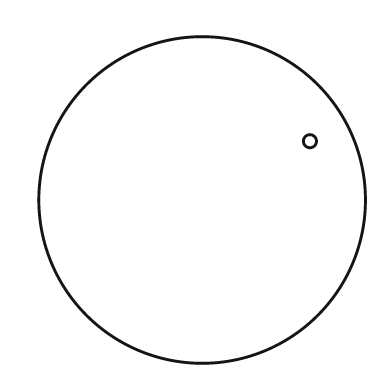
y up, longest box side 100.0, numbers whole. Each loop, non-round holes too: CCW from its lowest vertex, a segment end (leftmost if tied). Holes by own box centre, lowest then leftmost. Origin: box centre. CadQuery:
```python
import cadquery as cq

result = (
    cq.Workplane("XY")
    .moveTo(0.0, 0.0)
    .circle(50.0)
    .moveTo(33.0, 18.0)
    .circle(2.0)
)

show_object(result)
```